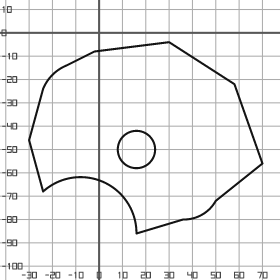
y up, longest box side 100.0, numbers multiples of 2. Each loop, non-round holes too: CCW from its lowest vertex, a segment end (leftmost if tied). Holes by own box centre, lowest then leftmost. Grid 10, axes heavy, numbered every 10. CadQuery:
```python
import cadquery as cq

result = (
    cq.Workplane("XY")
    .moveTo(16.0, -86.0)
    .lineTo(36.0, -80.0)
    .threePointArc((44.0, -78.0), (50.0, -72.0))
    .lineTo(70.0, -56.0)
    .lineTo(58.0, -22.0)
    .lineTo(30.0, -4.0)
    .lineTo(-2.0, -8.0)
    .lineTo(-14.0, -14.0)
    .threePointArc((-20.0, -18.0), (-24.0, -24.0))
    .lineTo(-30.0, -46.0)
    .lineTo(-24.0, -68.0)
    .threePointArc((2.0, -64.0), (16.0, -86.0))
    .close()
    .moveTo(16.0, -50.0)
    .circle(8.0)
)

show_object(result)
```